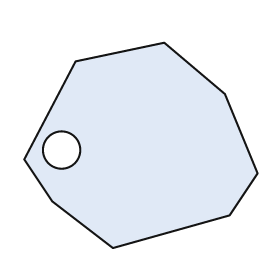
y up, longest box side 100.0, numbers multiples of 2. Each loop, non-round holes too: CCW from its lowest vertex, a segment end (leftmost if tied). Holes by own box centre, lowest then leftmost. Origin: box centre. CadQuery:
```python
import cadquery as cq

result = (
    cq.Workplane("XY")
    .moveTo(-12.0, -44.0)
    .lineTo(38.0, -30.0)
    .lineTo(50.0, -12.0)
    .lineTo(36.0, 22.0)
    .lineTo(10.0, 44.0)
    .lineTo(-28.0, 36.0)
    .lineTo(-50.0, -6.0)
    .lineTo(-38.0, -24.0)
    .close()
    .moveTo(-34.0, -2.0)
    .circle(8.0)
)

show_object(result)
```